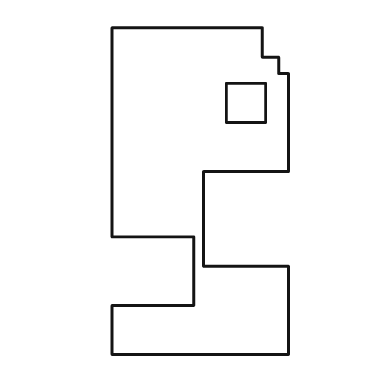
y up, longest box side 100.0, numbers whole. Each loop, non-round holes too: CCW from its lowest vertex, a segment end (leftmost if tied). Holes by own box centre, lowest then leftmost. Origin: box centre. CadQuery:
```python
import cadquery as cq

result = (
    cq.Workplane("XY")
    .moveTo(-27.0, -50.0)
    .lineTo(27.0, -50.0)
    .lineTo(27.0, -23.0)
    .lineTo(1.0, -23.0)
    .lineTo(1.0, 6.0)
    .lineTo(27.0, 6.0)
    .lineTo(27.0, 36.0)
    .lineTo(24.0, 36.0)
    .lineTo(24.0, 41.0)
    .lineTo(19.0, 41.0)
    .lineTo(19.0, 50.0)
    .lineTo(-27.0, 50.0)
    .lineTo(-27.0, -14.0)
    .lineTo(-2.0, -14.0)
    .lineTo(-2.0, -35.0)
    .lineTo(-27.0, -35.0)
    .close()
    .moveTo(8.0, 21.0)
    .lineTo(20.0, 21.0)
    .lineTo(20.0, 33.0)
    .lineTo(8.0, 33.0)
    .close()
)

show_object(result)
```